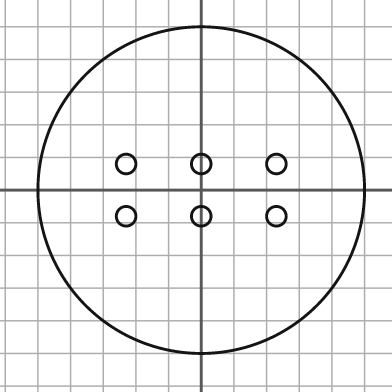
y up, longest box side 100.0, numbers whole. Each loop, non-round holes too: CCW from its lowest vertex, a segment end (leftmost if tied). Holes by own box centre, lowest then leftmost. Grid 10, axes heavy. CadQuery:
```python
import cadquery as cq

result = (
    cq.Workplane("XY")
    .moveTo(0.0, 0.0)
    .circle(50.0)
    .moveTo(-23.0, -8.0)
    .circle(3.0)
    .moveTo(0.0, -8.0)
    .circle(3.0)
    .moveTo(23.0, -8.0)
    .circle(3.0)
    .moveTo(-23.0, 8.0)
    .circle(3.0)
    .moveTo(0.0, 8.0)
    .circle(3.0)
    .moveTo(23.0, 8.0)
    .circle(3.0)
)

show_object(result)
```